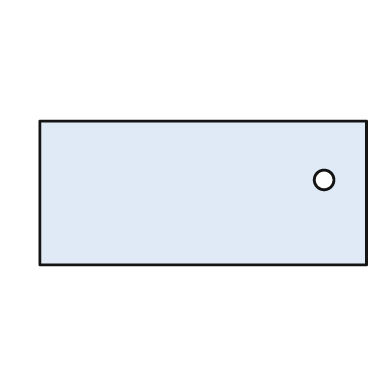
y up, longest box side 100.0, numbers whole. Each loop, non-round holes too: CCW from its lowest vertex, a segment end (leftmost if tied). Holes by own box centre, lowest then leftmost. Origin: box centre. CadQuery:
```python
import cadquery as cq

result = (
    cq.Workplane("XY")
    .moveTo(-50.0, -22.0)
    .lineTo(50.0, -22.0)
    .lineTo(50.0, 22.0)
    .lineTo(-50.0, 22.0)
    .close()
    .moveTo(37.0, 4.0)
    .circle(3.0)
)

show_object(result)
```